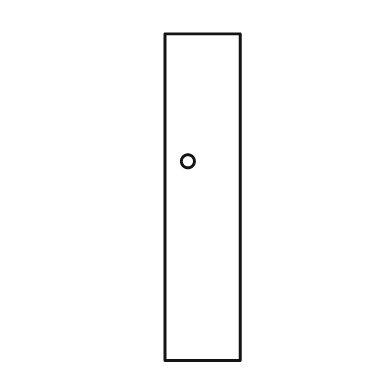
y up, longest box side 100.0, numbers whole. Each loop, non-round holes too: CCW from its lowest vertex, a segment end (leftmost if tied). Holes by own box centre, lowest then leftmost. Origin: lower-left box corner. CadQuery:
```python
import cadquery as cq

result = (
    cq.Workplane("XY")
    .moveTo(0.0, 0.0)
    .lineTo(23.0, 0.0)
    .lineTo(23.0, 100.0)
    .lineTo(0.0, 100.0)
    .close()
    .moveTo(7.0, 61.0)
    .circle(2.0)
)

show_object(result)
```